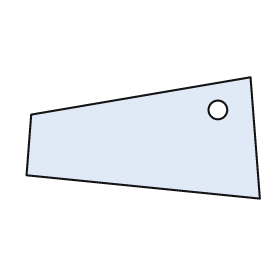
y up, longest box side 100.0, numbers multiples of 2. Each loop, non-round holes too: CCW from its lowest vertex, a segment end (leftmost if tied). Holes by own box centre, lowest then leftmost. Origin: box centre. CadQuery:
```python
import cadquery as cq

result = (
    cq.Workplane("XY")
    .moveTo(50.0, -26.0)
    .lineTo(46.0, 26.0)
    .lineTo(-48.0, 10.0)
    .lineTo(-50.0, -16.0)
    .close()
    .moveTo(32.0, 12.0)
    .circle(4.0)
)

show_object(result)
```